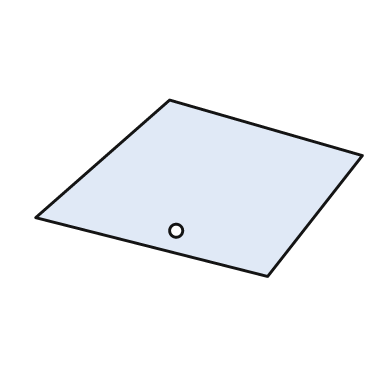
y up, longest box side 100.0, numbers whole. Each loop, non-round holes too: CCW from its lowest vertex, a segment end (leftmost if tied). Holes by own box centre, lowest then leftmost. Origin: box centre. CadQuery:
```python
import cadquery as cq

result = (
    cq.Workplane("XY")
    .moveTo(21.0, -27.0)
    .lineTo(50.0, 10.0)
    .lineTo(-9.0, 27.0)
    .lineTo(-50.0, -9.0)
    .close()
    .moveTo(-7.0, -13.0)
    .circle(2.0)
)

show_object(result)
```